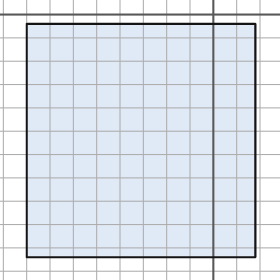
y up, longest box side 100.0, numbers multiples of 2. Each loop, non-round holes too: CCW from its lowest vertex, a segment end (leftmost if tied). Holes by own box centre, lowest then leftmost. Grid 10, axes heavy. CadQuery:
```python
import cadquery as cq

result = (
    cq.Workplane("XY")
    .moveTo(-80.0, -104.0)
    .lineTo(18.0, -104.0)
    .lineTo(18.0, -4.0)
    .lineTo(-80.0, -4.0)
    .close()
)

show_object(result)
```